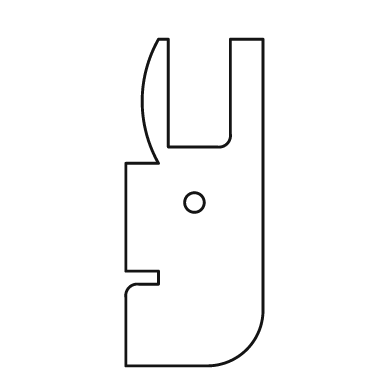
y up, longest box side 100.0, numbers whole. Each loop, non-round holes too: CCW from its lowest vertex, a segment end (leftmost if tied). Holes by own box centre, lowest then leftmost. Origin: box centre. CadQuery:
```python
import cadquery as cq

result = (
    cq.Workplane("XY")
    .moveTo(-21.0, -50.0)
    .lineTo(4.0, -50.0)
    .threePointArc((16.0, -45.0), (21.0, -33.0))
    .lineTo(21.0, 50.0)
    .lineTo(11.0, 50.0)
    .lineTo(11.0, 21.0)
    .threePointArc((10.0, 18.0), (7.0, 17.0))
    .lineTo(-8.0, 17.0)
    .lineTo(-8.0, 50.0)
    .lineTo(-11.0, 50.0)
    .threePointArc((-16.0, 31.0), (-11.0, 12.0))
    .lineTo(-21.0, 12.0)
    .lineTo(-21.0, -21.0)
    .lineTo(-11.0, -21.0)
    .lineTo(-11.0, -25.0)
    .lineTo(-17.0, -25.0)
    .threePointArc((-20.0, -26.0), (-21.0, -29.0))
    .close()
    .moveTo(0.0, 0.0)
    .circle(3.0)
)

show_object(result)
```